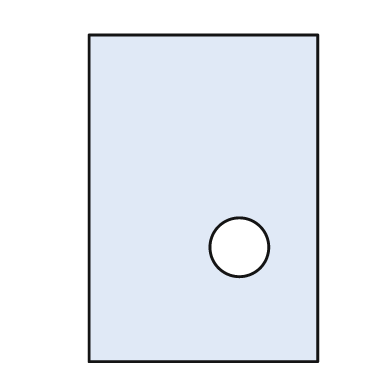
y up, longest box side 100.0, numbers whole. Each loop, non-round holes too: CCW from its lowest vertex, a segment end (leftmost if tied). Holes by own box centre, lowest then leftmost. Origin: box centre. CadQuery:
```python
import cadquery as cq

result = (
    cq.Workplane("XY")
    .moveTo(-35.0, -50.0)
    .lineTo(35.0, -50.0)
    .lineTo(35.0, 50.0)
    .lineTo(-35.0, 50.0)
    .close()
    .moveTo(11.0, -15.0)
    .circle(9.0)
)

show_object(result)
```